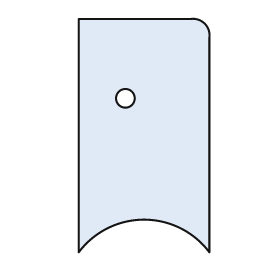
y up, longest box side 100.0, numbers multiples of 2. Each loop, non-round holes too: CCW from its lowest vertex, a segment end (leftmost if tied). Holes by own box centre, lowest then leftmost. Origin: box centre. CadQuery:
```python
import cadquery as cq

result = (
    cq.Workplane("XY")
    .moveTo(-28.0, -50.0)
    .threePointArc((0.0, -36.0), (28.0, -50.0))
    .lineTo(28.0, 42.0)
    .threePointArc((26.0, 48.0), (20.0, 50.0))
    .lineTo(-28.0, 50.0)
    .close()
    .moveTo(-8.0, 16.0)
    .circle(4.0)
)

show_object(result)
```